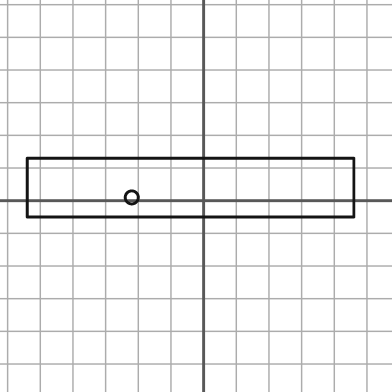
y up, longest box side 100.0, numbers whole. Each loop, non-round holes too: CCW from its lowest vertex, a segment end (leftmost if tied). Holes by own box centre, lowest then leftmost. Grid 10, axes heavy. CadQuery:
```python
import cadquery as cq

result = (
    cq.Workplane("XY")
    .moveTo(-54.0, -5.0)
    .lineTo(46.0, -5.0)
    .lineTo(46.0, 13.0)
    .lineTo(-54.0, 13.0)
    .close()
    .moveTo(-22.0, 1.0)
    .circle(2.0)
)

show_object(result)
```